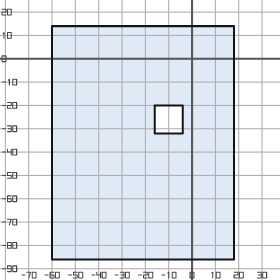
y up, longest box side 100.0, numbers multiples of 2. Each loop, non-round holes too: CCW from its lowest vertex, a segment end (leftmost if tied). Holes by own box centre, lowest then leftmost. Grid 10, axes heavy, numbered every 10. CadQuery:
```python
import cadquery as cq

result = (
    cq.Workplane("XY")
    .moveTo(-60.0, -86.0)
    .lineTo(18.0, -86.0)
    .lineTo(18.0, 14.0)
    .lineTo(-60.0, 14.0)
    .close()
    .moveTo(-16.0, -32.0)
    .lineTo(-4.0, -32.0)
    .lineTo(-4.0, -20.0)
    .lineTo(-16.0, -20.0)
    .close()
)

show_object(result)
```